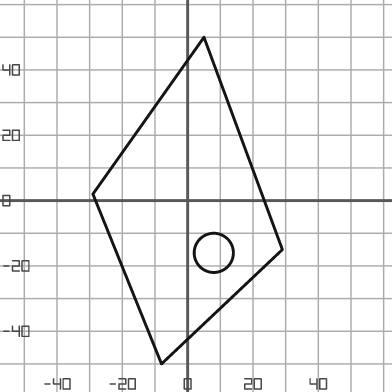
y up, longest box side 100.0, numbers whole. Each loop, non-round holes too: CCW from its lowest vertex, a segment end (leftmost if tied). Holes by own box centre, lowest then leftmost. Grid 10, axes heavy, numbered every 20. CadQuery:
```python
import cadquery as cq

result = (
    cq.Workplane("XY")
    .moveTo(-8.0, -50.0)
    .lineTo(29.0, -15.0)
    .lineTo(5.0, 50.0)
    .lineTo(-29.0, 2.0)
    .close()
    .moveTo(8.0, -16.0)
    .circle(6.0)
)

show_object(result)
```